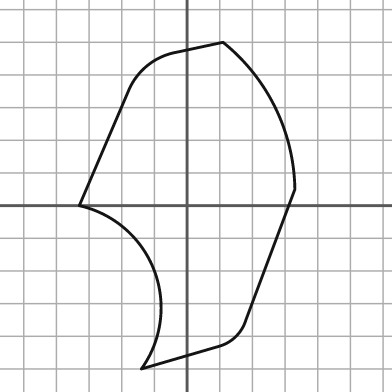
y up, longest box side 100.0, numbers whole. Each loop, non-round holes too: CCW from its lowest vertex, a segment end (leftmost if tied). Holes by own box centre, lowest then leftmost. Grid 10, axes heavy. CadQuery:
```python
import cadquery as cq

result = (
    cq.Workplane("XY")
    .moveTo(-14.0, -50.0)
    .lineTo(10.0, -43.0)
    .threePointArc((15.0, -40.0), (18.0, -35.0))
    .lineTo(33.0, 5.0)
    .threePointArc((27.0, 30.0), (11.0, 50.0))
    .lineTo(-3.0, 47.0)
    .threePointArc((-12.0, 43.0), (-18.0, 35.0))
    .lineTo(-33.0, 0.0)
    .threePointArc((-10.0, -20.0), (-14.0, -50.0))
    .close()
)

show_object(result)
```